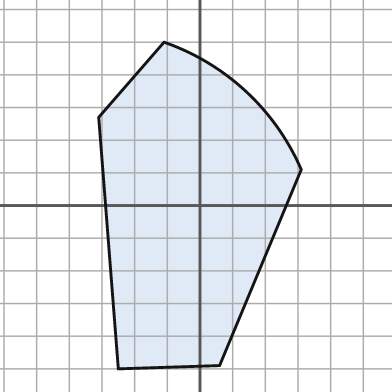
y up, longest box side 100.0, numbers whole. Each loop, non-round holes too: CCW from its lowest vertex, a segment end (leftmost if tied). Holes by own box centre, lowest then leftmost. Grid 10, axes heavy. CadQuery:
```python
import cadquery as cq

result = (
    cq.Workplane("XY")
    .moveTo(-25.0, -50.0)
    .lineTo(6.0, -49.0)
    .lineTo(31.0, 11.0)
    .threePointArc((14.0, 35.0), (-11.0, 50.0))
    .lineTo(-31.0, 27.0)
    .close()
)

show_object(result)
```